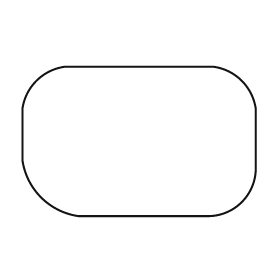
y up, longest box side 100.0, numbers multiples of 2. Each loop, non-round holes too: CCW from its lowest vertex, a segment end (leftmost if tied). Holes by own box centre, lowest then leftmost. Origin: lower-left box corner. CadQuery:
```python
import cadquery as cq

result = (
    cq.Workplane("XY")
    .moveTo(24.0, 0.0)
    .lineTo(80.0, 0.0)
    .threePointArc((94.0, 6.0), (100.0, 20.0))
    .lineTo(100.0, 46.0)
    .threePointArc((94.0, 58.0), (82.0, 64.0))
    .lineTo(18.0, 64.0)
    .threePointArc((6.0, 58.0), (0.0, 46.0))
    .lineTo(0.0, 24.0)
    .threePointArc((8.0, 8.0), (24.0, 0.0))
    .close()
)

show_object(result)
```